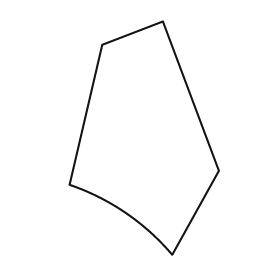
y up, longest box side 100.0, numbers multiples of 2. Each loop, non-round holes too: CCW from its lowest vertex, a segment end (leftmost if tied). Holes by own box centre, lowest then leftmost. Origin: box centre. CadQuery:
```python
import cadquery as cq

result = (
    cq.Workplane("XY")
    .moveTo(12.0, -50.0)
    .lineTo(32.0, -14.0)
    .lineTo(8.0, 50.0)
    .lineTo(-18.0, 40.0)
    .lineTo(-32.0, -20.0)
    .threePointArc((-8.0, -32.0), (12.0, -50.0))
    .close()
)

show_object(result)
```